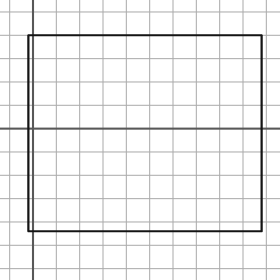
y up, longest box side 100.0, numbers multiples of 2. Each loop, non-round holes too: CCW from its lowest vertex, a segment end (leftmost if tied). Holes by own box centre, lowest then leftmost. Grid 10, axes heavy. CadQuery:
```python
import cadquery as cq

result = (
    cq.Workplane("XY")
    .moveTo(-2.0, -44.0)
    .lineTo(98.0, -44.0)
    .lineTo(98.0, 40.0)
    .lineTo(-2.0, 40.0)
    .close()
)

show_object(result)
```